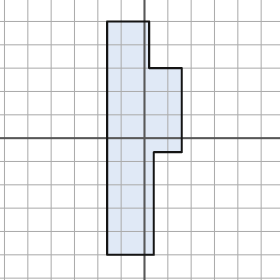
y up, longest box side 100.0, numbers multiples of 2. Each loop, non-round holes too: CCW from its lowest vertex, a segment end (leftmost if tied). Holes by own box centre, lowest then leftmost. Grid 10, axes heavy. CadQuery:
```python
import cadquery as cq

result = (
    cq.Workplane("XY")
    .moveTo(-16.0, -50.0)
    .lineTo(4.0, -50.0)
    .lineTo(4.0, -6.0)
    .lineTo(16.0, -6.0)
    .lineTo(16.0, 30.0)
    .lineTo(2.0, 30.0)
    .lineTo(2.0, 50.0)
    .lineTo(-16.0, 50.0)
    .close()
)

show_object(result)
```